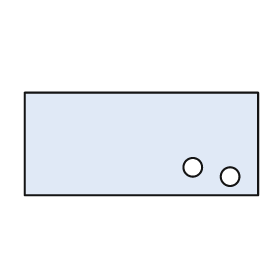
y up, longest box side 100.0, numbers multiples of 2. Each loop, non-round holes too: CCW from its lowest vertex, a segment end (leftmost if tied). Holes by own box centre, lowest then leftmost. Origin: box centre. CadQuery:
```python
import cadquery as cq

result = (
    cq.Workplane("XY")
    .moveTo(-50.0, -22.0)
    .lineTo(50.0, -22.0)
    .lineTo(50.0, 22.0)
    .lineTo(-50.0, 22.0)
    .close()
    .moveTo(38.0, -14.0)
    .circle(4.0)
    .moveTo(22.0, -10.0)
    .circle(4.0)
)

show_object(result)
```